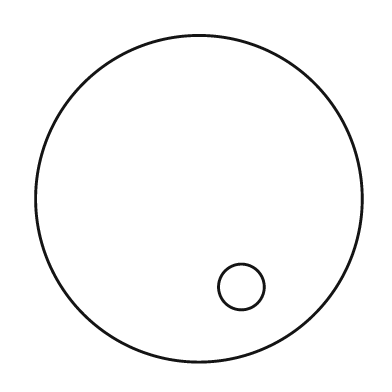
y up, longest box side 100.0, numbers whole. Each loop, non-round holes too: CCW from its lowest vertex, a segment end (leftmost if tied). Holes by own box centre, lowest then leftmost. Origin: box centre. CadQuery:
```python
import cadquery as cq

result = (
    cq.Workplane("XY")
    .moveTo(0.0, 0.0)
    .circle(50.0)
    .moveTo(13.0, -27.0)
    .circle(7.0)
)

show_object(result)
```